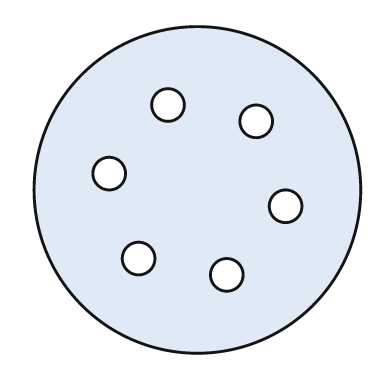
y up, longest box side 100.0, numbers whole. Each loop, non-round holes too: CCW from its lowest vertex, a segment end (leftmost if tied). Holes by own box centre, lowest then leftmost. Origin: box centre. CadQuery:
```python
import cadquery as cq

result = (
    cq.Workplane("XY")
    .moveTo(0.0, 0.0)
    .circle(50.0)
    .moveTo(9.0, -26.0)
    .circle(5.0)
    .moveTo(-18.0, -21.0)
    .circle(5.0)
    .moveTo(27.0, -5.0)
    .circle(5.0)
    .moveTo(-27.0, 5.0)
    .circle(5.0)
    .moveTo(18.0, 21.0)
    .circle(5.0)
    .moveTo(-9.0, 26.0)
    .circle(5.0)
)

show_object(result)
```